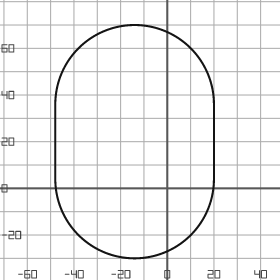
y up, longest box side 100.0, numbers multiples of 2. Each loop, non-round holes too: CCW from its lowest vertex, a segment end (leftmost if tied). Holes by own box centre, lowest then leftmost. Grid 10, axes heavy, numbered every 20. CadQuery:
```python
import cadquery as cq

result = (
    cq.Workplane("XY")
    .moveTo(-48.0, 4.0)
    .threePointArc((-14.0, -30.0), (20.0, 4.0))
    .lineTo(20.0, 36.0)
    .threePointArc((-14.0, 70.0), (-48.0, 36.0))
    .close()
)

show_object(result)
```